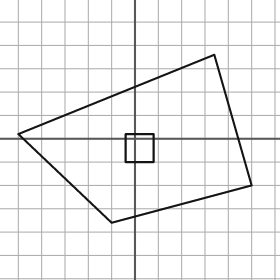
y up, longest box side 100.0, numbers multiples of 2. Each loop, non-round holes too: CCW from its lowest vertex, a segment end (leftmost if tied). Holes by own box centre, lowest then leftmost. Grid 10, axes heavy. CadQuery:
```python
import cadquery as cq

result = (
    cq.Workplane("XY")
    .moveTo(-10.0, -36.0)
    .lineTo(50.0, -20.0)
    .lineTo(34.0, 36.0)
    .lineTo(-50.0, 2.0)
    .close()
    .moveTo(-4.0, -10.0)
    .lineTo(8.0, -10.0)
    .lineTo(8.0, 2.0)
    .lineTo(-4.0, 2.0)
    .close()
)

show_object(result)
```